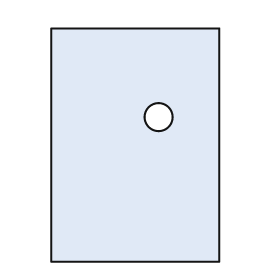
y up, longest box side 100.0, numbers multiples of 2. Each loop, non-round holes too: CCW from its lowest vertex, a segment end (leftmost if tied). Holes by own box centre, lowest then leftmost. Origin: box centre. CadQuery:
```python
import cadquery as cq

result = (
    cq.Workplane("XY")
    .moveTo(-36.0, -50.0)
    .lineTo(36.0, -50.0)
    .lineTo(36.0, 50.0)
    .lineTo(-36.0, 50.0)
    .close()
    .moveTo(10.0, 12.0)
    .circle(6.0)
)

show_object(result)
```